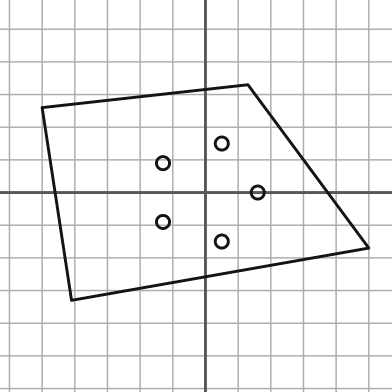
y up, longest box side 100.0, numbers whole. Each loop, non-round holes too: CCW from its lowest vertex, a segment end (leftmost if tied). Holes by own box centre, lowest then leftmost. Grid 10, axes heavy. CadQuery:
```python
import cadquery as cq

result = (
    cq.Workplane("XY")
    .moveTo(-41.0, -33.0)
    .lineTo(50.0, -17.0)
    .lineTo(13.0, 33.0)
    .lineTo(-50.0, 26.0)
    .close()
    .moveTo(5.0, -15.0)
    .circle(2.0)
    .moveTo(-13.0, -9.0)
    .circle(2.0)
    .moveTo(16.0, 0.0)
    .circle(2.0)
    .moveTo(-13.0, 9.0)
    .circle(2.0)
    .moveTo(5.0, 15.0)
    .circle(2.0)
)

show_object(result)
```